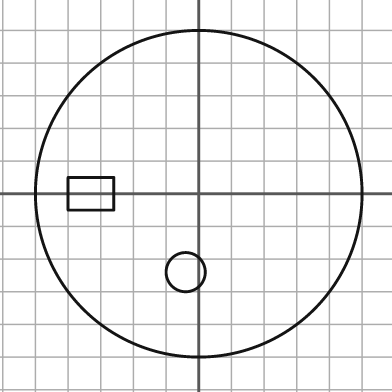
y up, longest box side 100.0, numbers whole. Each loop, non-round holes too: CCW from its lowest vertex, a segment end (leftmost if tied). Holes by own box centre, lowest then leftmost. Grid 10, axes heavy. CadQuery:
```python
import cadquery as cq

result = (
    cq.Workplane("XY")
    .moveTo(0.0, 0.0)
    .circle(50.0)
    .moveTo(-4.0, -24.0)
    .circle(6.0)
    .moveTo(-40.0, -5.0)
    .lineTo(-26.0, -5.0)
    .lineTo(-26.0, 5.0)
    .lineTo(-40.0, 5.0)
    .close()
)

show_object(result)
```